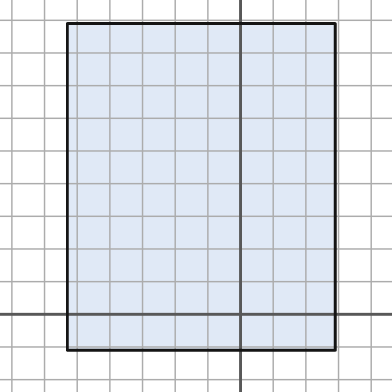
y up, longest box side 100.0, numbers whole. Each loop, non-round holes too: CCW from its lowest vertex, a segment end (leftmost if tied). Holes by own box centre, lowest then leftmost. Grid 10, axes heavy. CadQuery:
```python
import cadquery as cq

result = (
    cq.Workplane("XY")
    .moveTo(-53.0, -11.0)
    .lineTo(29.0, -11.0)
    .lineTo(29.0, 89.0)
    .lineTo(-53.0, 89.0)
    .close()
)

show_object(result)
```